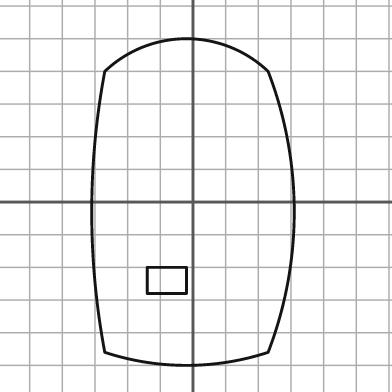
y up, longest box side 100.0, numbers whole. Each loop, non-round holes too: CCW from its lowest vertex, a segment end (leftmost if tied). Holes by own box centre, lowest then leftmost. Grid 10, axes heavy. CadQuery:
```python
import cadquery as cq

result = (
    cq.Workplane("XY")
    .moveTo(-27.0, -46.0)
    .threePointArc((-2.0, -50.0), (23.0, -46.0))
    .threePointArc((31.0, -3.0), (23.0, 40.0))
    .threePointArc((-2.0, 50.0), (-27.0, 40.0))
    .threePointArc((-31.0, -3.0), (-27.0, -46.0))
    .close()
    .moveTo(-14.0, -28.0)
    .lineTo(-2.0, -28.0)
    .lineTo(-2.0, -20.0)
    .lineTo(-14.0, -20.0)
    .close()
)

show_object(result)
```